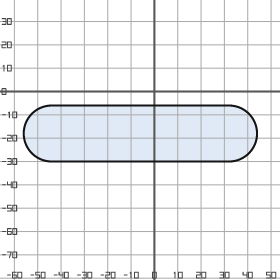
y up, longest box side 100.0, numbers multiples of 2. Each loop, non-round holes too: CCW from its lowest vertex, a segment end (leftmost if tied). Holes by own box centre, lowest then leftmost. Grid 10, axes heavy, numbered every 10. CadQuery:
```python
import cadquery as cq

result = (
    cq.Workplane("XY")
    .moveTo(-44.0, -30.0)
    .lineTo(32.0, -30.0)
    .threePointArc((44.0, -18.0), (32.0, -6.0))
    .lineTo(-44.0, -6.0)
    .threePointArc((-56.0, -18.0), (-44.0, -30.0))
    .close()
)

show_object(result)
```